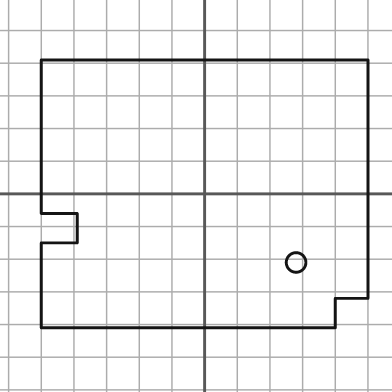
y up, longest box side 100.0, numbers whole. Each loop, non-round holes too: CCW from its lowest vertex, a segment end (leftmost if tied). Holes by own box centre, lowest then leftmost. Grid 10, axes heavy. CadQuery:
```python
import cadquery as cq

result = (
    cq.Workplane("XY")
    .moveTo(-50.0, -41.0)
    .lineTo(40.0, -41.0)
    .lineTo(40.0, -32.0)
    .lineTo(50.0, -32.0)
    .lineTo(50.0, 41.0)
    .lineTo(-50.0, 41.0)
    .lineTo(-50.0, -6.0)
    .lineTo(-39.0, -6.0)
    .lineTo(-39.0, -15.0)
    .lineTo(-50.0, -15.0)
    .close()
    .moveTo(28.0, -21.0)
    .circle(3.0)
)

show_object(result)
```